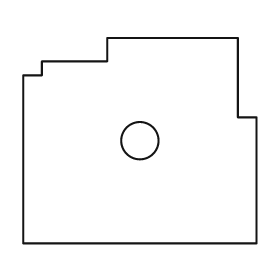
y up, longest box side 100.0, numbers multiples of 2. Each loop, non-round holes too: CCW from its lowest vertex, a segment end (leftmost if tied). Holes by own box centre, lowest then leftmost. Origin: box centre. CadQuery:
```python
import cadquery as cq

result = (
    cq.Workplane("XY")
    .moveTo(-50.0, -44.0)
    .lineTo(50.0, -44.0)
    .lineTo(50.0, 10.0)
    .lineTo(42.0, 10.0)
    .lineTo(42.0, 44.0)
    .lineTo(-14.0, 44.0)
    .lineTo(-14.0, 34.0)
    .lineTo(-42.0, 34.0)
    .lineTo(-42.0, 28.0)
    .lineTo(-50.0, 28.0)
    .close()
    .moveTo(0.0, 0.0)
    .circle(8.0)
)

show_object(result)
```